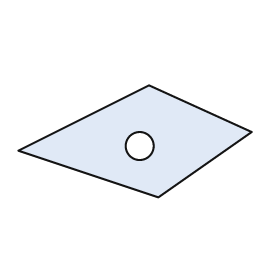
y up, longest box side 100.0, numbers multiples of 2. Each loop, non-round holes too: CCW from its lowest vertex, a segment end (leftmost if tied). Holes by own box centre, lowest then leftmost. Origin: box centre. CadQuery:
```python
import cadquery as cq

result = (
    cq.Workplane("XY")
    .moveTo(10.0, -24.0)
    .lineTo(50.0, 4.0)
    .lineTo(6.0, 24.0)
    .lineTo(-50.0, -4.0)
    .close()
    .moveTo(2.0, -2.0)
    .circle(6.0)
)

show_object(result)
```